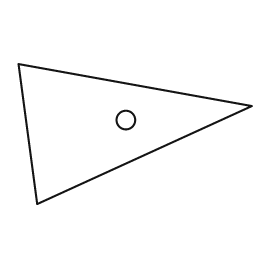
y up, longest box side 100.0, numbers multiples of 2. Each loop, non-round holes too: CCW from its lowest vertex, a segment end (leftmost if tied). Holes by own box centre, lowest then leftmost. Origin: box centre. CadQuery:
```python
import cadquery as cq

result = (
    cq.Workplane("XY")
    .moveTo(-42.0, -30.0)
    .lineTo(50.0, 12.0)
    .lineTo(-50.0, 30.0)
    .close()
    .moveTo(-4.0, 6.0)
    .circle(4.0)
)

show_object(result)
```